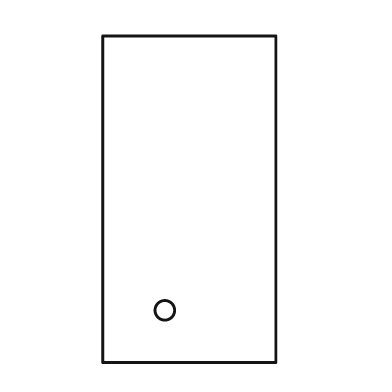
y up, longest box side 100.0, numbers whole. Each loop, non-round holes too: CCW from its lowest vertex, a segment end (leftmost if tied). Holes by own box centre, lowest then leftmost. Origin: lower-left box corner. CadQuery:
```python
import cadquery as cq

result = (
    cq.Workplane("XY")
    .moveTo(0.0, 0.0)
    .lineTo(53.0, 0.0)
    .lineTo(53.0, 100.0)
    .lineTo(0.0, 100.0)
    .close()
    .moveTo(19.0, 16.0)
    .circle(3.0)
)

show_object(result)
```